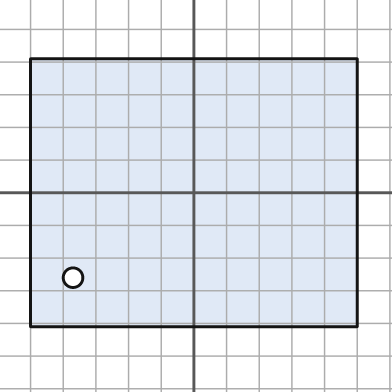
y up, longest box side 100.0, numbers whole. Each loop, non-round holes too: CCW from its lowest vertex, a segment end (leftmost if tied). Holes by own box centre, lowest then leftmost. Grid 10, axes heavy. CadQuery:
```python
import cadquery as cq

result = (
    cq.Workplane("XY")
    .moveTo(-50.0, -41.0)
    .lineTo(50.0, -41.0)
    .lineTo(50.0, 41.0)
    .lineTo(-50.0, 41.0)
    .close()
    .moveTo(-37.0, -26.0)
    .circle(3.0)
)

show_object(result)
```